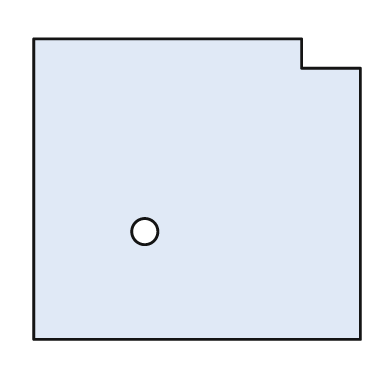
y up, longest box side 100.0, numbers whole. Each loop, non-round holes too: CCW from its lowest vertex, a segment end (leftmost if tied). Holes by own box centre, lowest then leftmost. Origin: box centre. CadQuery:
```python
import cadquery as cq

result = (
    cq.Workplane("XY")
    .moveTo(-50.0, -46.0)
    .lineTo(50.0, -46.0)
    .lineTo(50.0, 37.0)
    .lineTo(32.0, 37.0)
    .lineTo(32.0, 46.0)
    .lineTo(-50.0, 46.0)
    .close()
    .moveTo(-16.0, -13.0)
    .circle(4.0)
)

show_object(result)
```